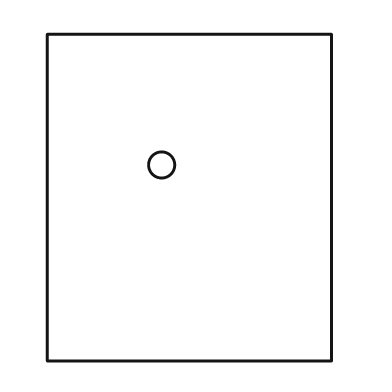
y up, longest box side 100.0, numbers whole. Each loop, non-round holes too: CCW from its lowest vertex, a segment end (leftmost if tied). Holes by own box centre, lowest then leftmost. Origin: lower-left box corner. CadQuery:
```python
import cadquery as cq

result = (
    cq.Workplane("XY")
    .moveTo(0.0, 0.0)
    .lineTo(87.0, 0.0)
    .lineTo(87.0, 100.0)
    .lineTo(0.0, 100.0)
    .close()
    .moveTo(35.0, 60.0)
    .circle(4.0)
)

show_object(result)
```